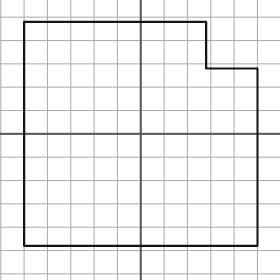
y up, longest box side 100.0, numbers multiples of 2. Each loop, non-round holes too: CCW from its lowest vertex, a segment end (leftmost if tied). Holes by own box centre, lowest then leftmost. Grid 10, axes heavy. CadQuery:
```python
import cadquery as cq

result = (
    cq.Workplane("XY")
    .moveTo(-50.0, -48.0)
    .lineTo(50.0, -48.0)
    .lineTo(50.0, 28.0)
    .lineTo(28.0, 28.0)
    .lineTo(28.0, 48.0)
    .lineTo(-50.0, 48.0)
    .close()
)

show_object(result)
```